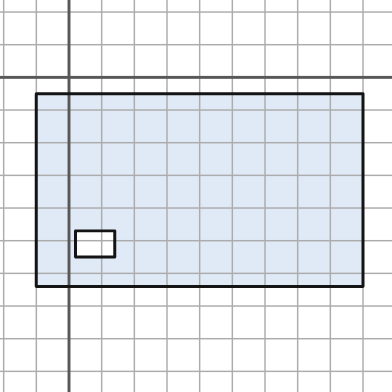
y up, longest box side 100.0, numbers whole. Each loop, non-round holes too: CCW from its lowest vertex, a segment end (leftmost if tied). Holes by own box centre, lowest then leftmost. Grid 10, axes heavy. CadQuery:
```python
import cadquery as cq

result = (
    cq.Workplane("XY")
    .moveTo(-10.0, -64.0)
    .lineTo(90.0, -64.0)
    .lineTo(90.0, -5.0)
    .lineTo(-10.0, -5.0)
    .close()
    .moveTo(2.0, -55.0)
    .lineTo(14.0, -55.0)
    .lineTo(14.0, -47.0)
    .lineTo(2.0, -47.0)
    .close()
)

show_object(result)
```